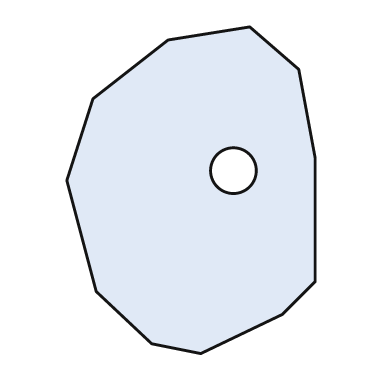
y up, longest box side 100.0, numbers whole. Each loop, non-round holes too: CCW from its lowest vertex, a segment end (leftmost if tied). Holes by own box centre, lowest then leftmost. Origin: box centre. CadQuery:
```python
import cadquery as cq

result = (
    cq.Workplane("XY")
    .moveTo(3.0, -50.0)
    .lineTo(28.0, -38.0)
    .lineTo(38.0, -28.0)
    .lineTo(38.0, 10.0)
    .lineTo(33.0, 37.0)
    .lineTo(18.0, 50.0)
    .lineTo(-7.0, 46.0)
    .lineTo(-30.0, 28.0)
    .lineTo(-38.0, 3.0)
    .lineTo(-29.0, -31.0)
    .lineTo(-12.0, -47.0)
    .close()
    .moveTo(13.0, 6.0)
    .circle(7.0)
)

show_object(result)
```